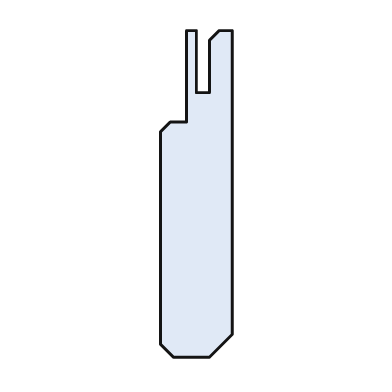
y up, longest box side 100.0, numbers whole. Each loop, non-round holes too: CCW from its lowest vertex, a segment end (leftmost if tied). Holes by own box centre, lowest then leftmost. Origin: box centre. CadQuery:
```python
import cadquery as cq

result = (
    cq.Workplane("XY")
    .moveTo(-7.0, -50.0)
    .lineTo(4.0, -50.0)
    .lineTo(11.0, -43.0)
    .lineTo(11.0, 50.0)
    .lineTo(7.0, 50.0)
    .lineTo(4.0, 47.0)
    .lineTo(4.0, 31.0)
    .lineTo(0.0, 31.0)
    .lineTo(0.0, 50.0)
    .lineTo(-3.0, 50.0)
    .lineTo(-3.0, 22.0)
    .lineTo(-8.0, 22.0)
    .lineTo(-11.0, 19.0)
    .lineTo(-11.0, -46.0)
    .close()
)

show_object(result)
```